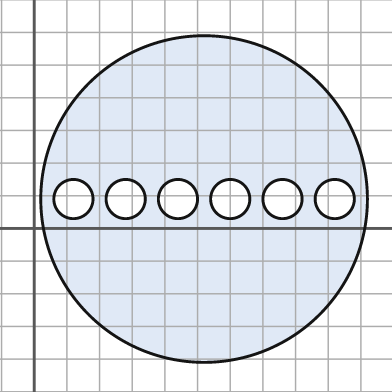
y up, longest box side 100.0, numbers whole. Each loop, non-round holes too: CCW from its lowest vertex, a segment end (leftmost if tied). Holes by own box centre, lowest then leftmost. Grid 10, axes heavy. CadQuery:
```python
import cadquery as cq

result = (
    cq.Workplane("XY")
    .moveTo(52.0, 9.0)
    .circle(50.0)
    .moveTo(12.0, 9.0)
    .circle(6.0)
    .moveTo(28.0, 9.0)
    .circle(6.0)
    .moveTo(44.0, 9.0)
    .circle(6.0)
    .moveTo(60.0, 9.0)
    .circle(6.0)
    .moveTo(76.0, 9.0)
    .circle(6.0)
    .moveTo(92.0, 9.0)
    .circle(6.0)
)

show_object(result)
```